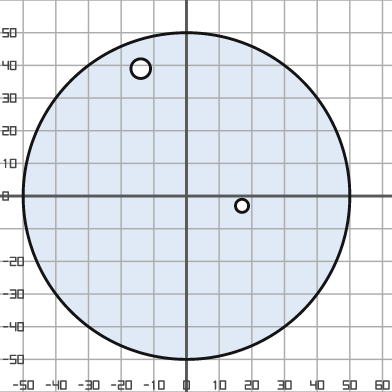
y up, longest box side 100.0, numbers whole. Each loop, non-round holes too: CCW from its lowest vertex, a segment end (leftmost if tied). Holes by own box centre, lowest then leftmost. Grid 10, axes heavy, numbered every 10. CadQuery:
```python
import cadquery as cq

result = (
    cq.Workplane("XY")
    .moveTo(0.0, 0.0)
    .circle(50.0)
    .moveTo(17.0, -3.0)
    .circle(2.0)
    .moveTo(-14.0, 39.0)
    .circle(3.0)
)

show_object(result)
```